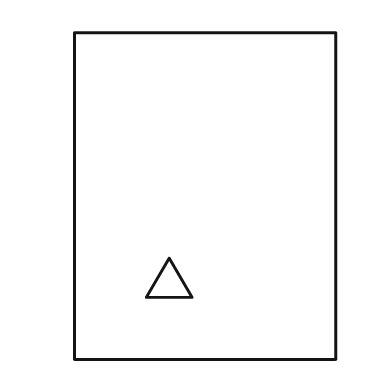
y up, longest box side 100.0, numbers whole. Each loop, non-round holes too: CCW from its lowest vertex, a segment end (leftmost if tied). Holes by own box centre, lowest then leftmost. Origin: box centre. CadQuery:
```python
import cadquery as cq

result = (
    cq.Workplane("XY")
    .moveTo(-40.0, -50.0)
    .lineTo(40.0, -50.0)
    .lineTo(40.0, 50.0)
    .lineTo(-40.0, 50.0)
    .close()
    .moveTo(-18.0, -31.0)
    .lineTo(-4.0, -31.0)
    .lineTo(-11.0, -19.0)
    .close()
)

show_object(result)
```